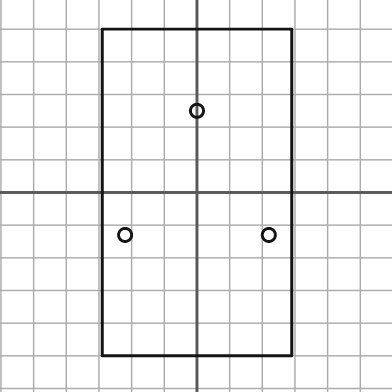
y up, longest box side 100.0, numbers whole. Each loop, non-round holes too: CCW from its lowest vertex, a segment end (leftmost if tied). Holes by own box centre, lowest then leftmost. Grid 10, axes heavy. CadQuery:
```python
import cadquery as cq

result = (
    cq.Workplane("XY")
    .moveTo(-29.0, -50.0)
    .lineTo(29.0, -50.0)
    .lineTo(29.0, 50.0)
    .lineTo(-29.0, 50.0)
    .close()
    .moveTo(-22.0, -13.0)
    .circle(2.0)
    .moveTo(22.0, -13.0)
    .circle(2.0)
    .moveTo(0.0, 25.0)
    .circle(2.0)
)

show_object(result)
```